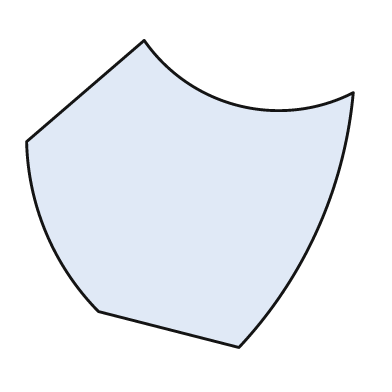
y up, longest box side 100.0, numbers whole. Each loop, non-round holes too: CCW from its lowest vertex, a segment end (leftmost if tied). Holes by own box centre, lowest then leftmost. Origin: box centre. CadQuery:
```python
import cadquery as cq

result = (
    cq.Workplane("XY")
    .moveTo(15.0, -47.0)
    .threePointArc((39.0, -11.0), (50.0, 31.0))
    .threePointArc((15.0, 27.0), (-14.0, 47.0))
    .lineTo(-50.0, 16.0)
    .threePointArc((-44.0, -12.0), (-28.0, -36.0))
    .close()
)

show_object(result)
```